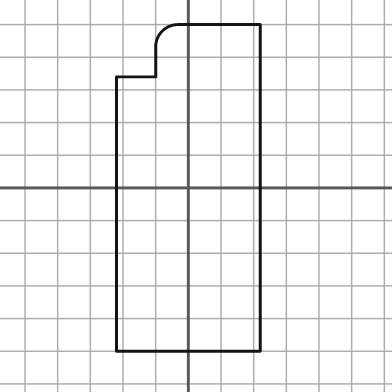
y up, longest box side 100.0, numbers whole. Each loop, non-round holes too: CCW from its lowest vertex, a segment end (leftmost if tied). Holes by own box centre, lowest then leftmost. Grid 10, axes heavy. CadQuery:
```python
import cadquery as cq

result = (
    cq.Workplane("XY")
    .moveTo(-22.0, -50.0)
    .lineTo(22.0, -50.0)
    .lineTo(22.0, 50.0)
    .lineTo(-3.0, 50.0)
    .threePointArc((-8.0, 48.0), (-10.0, 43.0))
    .lineTo(-10.0, 34.0)
    .lineTo(-22.0, 34.0)
    .close()
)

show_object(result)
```